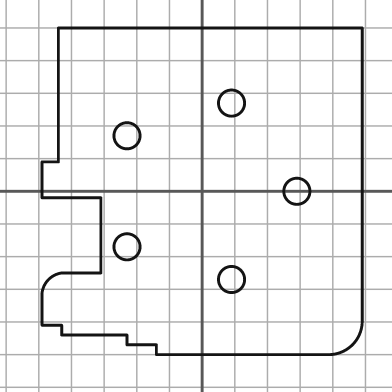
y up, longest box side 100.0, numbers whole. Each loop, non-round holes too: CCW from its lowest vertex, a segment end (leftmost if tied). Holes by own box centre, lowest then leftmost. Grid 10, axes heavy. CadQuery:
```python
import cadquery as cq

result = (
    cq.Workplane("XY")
    .moveTo(-14.0, -50.0)
    .lineTo(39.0, -50.0)
    .threePointArc((46.0, -47.0), (49.0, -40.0))
    .lineTo(49.0, 50.0)
    .lineTo(-44.0, 50.0)
    .lineTo(-44.0, 9.0)
    .lineTo(-49.0, 9.0)
    .lineTo(-49.0, -2.0)
    .lineTo(-31.0, -2.0)
    .lineTo(-31.0, -25.0)
    .lineTo(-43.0, -25.0)
    .threePointArc((-47.0, -27.0), (-49.0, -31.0))
    .lineTo(-49.0, -41.0)
    .lineTo(-43.0, -41.0)
    .lineTo(-43.0, -44.0)
    .lineTo(-23.0, -44.0)
    .lineTo(-23.0, -47.0)
    .lineTo(-14.0, -47.0)
    .close()
    .moveTo(9.0, -27.0)
    .circle(4.0)
    .moveTo(-23.0, -17.0)
    .circle(4.0)
    .moveTo(29.0, 0.0)
    .circle(4.0)
    .moveTo(-23.0, 17.0)
    .circle(4.0)
    .moveTo(9.0, 27.0)
    .circle(4.0)
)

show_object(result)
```